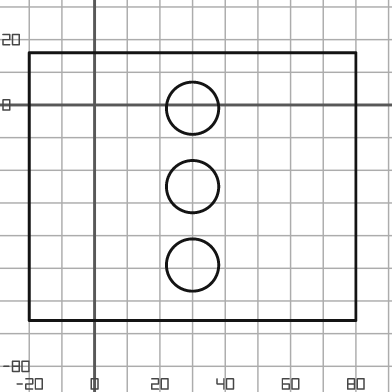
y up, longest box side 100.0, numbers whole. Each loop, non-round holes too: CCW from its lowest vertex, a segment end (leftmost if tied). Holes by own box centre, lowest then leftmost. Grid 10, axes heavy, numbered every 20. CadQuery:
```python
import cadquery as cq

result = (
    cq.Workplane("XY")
    .moveTo(-20.0, -66.0)
    .lineTo(80.0, -66.0)
    .lineTo(80.0, 16.0)
    .lineTo(-20.0, 16.0)
    .close()
    .moveTo(30.0, -49.0)
    .circle(8.0)
    .moveTo(30.0, -25.0)
    .circle(8.0)
    .moveTo(30.0, -1.0)
    .circle(8.0)
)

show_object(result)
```